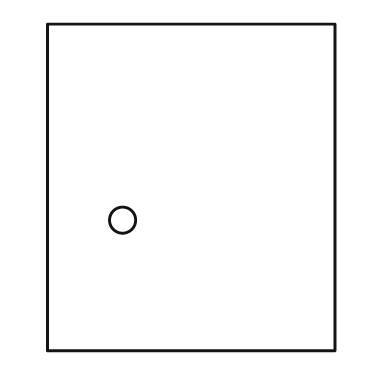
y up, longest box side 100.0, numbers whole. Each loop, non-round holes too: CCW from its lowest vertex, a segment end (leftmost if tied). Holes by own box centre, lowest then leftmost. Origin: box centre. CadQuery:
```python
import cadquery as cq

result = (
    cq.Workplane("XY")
    .moveTo(-44.0, -50.0)
    .lineTo(44.0, -50.0)
    .lineTo(44.0, 50.0)
    .lineTo(-44.0, 50.0)
    .close()
    .moveTo(-21.0, -10.0)
    .circle(4.0)
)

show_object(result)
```